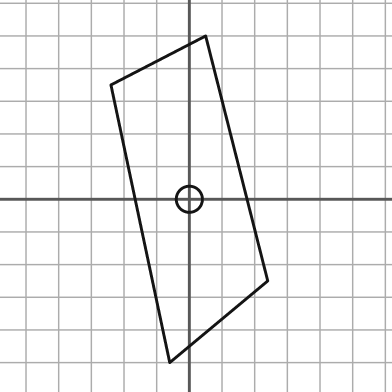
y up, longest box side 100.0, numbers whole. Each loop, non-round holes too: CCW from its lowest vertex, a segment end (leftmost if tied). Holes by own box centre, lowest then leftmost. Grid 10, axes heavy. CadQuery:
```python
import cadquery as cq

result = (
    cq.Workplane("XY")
    .moveTo(-6.0, -50.0)
    .lineTo(24.0, -25.0)
    .lineTo(5.0, 50.0)
    .lineTo(-24.0, 35.0)
    .close()
    .moveTo(0.0, 0.0)
    .circle(4.0)
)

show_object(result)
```